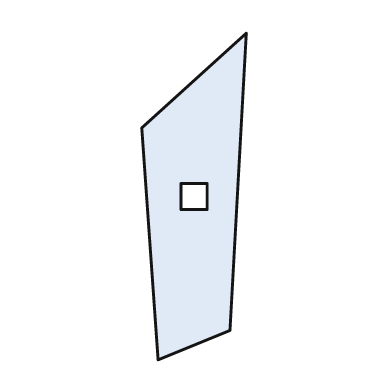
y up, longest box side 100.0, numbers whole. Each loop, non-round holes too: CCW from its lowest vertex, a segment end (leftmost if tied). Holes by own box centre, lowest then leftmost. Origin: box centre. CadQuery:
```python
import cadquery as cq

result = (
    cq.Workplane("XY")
    .moveTo(-11.0, -50.0)
    .lineTo(11.0, -41.0)
    .lineTo(16.0, 50.0)
    .lineTo(-16.0, 21.0)
    .close()
    .moveTo(-4.0, -4.0)
    .lineTo(4.0, -4.0)
    .lineTo(4.0, 4.0)
    .lineTo(-4.0, 4.0)
    .close()
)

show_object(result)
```